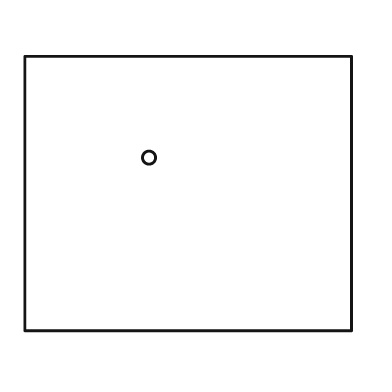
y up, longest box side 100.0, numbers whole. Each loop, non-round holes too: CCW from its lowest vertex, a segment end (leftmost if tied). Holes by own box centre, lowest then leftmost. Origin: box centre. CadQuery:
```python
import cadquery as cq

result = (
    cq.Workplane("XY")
    .moveTo(-50.0, -42.0)
    .lineTo(50.0, -42.0)
    .lineTo(50.0, 42.0)
    .lineTo(-50.0, 42.0)
    .close()
    .moveTo(-12.0, 11.0)
    .circle(2.0)
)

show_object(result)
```